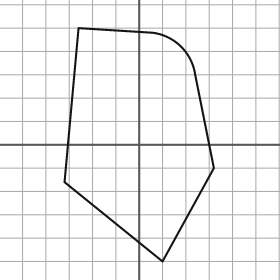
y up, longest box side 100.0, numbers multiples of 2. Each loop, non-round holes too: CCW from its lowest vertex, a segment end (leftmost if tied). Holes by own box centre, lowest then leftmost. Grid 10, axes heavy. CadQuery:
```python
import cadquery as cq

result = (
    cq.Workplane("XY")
    .moveTo(10.0, -50.0)
    .lineTo(32.0, -10.0)
    .lineTo(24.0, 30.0)
    .threePointArc((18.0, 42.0), (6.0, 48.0))
    .lineTo(-26.0, 50.0)
    .lineTo(-32.0, -16.0)
    .close()
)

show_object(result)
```